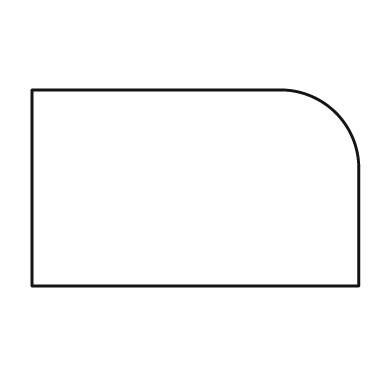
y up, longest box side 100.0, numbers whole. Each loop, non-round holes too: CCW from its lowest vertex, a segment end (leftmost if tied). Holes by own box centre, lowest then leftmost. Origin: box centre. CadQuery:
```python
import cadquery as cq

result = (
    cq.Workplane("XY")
    .moveTo(-50.0, -30.0)
    .lineTo(50.0, -30.0)
    .lineTo(50.0, 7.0)
    .threePointArc((43.0, 23.0), (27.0, 30.0))
    .lineTo(-50.0, 30.0)
    .close()
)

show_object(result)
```